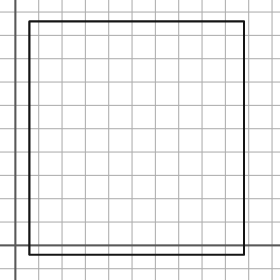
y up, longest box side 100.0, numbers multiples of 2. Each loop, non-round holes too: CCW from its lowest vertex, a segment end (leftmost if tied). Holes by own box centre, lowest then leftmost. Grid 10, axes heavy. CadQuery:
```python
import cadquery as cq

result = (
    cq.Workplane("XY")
    .moveTo(6.0, -4.0)
    .lineTo(98.0, -4.0)
    .lineTo(98.0, 96.0)
    .lineTo(6.0, 96.0)
    .close()
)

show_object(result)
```